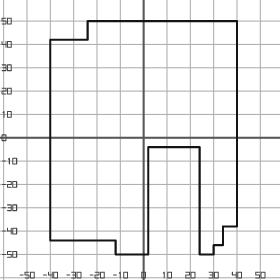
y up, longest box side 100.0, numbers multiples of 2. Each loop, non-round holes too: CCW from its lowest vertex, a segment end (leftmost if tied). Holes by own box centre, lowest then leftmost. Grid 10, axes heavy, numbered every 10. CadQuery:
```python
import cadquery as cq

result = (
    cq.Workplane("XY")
    .moveTo(-12.0, -50.0)
    .lineTo(2.0, -50.0)
    .lineTo(2.0, -4.0)
    .lineTo(24.0, -4.0)
    .lineTo(24.0, -50.0)
    .lineTo(30.0, -50.0)
    .lineTo(30.0, -46.0)
    .lineTo(34.0, -46.0)
    .lineTo(34.0, -38.0)
    .lineTo(40.0, -38.0)
    .lineTo(40.0, 50.0)
    .lineTo(-24.0, 50.0)
    .lineTo(-24.0, 42.0)
    .lineTo(-40.0, 42.0)
    .lineTo(-40.0, -44.0)
    .lineTo(-12.0, -44.0)
    .close()
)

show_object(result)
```